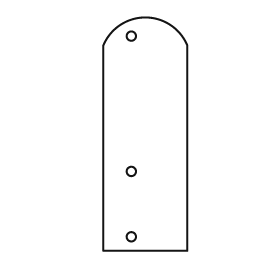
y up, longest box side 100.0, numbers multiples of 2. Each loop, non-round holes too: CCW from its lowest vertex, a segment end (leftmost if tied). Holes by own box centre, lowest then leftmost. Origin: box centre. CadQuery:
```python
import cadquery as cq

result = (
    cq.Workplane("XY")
    .moveTo(-18.0, -50.0)
    .lineTo(18.0, -50.0)
    .lineTo(18.0, 38.0)
    .threePointArc((0.0, 50.0), (-18.0, 38.0))
    .close()
    .moveTo(-6.0, -44.0)
    .circle(2.0)
    .moveTo(-6.0, -16.0)
    .circle(2.0)
    .moveTo(-6.0, 42.0)
    .circle(2.0)
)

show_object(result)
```